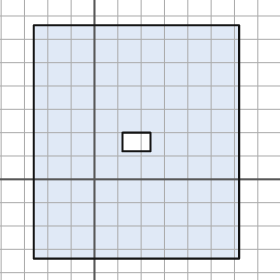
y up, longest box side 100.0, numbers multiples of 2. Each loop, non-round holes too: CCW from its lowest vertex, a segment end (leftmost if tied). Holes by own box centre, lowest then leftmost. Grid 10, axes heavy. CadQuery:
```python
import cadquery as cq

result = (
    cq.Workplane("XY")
    .moveTo(-26.0, -34.0)
    .lineTo(62.0, -34.0)
    .lineTo(62.0, 66.0)
    .lineTo(-26.0, 66.0)
    .close()
    .moveTo(12.0, 12.0)
    .lineTo(24.0, 12.0)
    .lineTo(24.0, 20.0)
    .lineTo(12.0, 20.0)
    .close()
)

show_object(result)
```